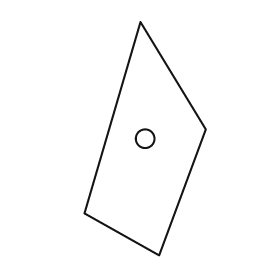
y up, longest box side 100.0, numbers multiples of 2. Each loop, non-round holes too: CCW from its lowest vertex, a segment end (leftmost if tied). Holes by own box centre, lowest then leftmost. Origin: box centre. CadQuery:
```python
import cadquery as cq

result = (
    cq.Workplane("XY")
    .moveTo(6.0, -50.0)
    .lineTo(26.0, 4.0)
    .lineTo(-2.0, 50.0)
    .lineTo(-26.0, -32.0)
    .close()
    .moveTo(0.0, 0.0)
    .circle(4.0)
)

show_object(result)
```